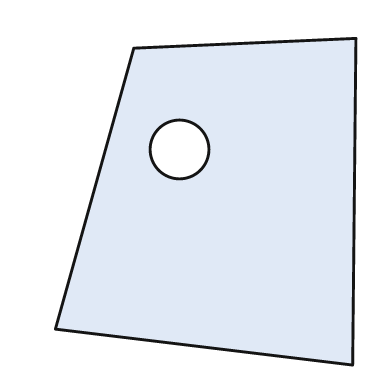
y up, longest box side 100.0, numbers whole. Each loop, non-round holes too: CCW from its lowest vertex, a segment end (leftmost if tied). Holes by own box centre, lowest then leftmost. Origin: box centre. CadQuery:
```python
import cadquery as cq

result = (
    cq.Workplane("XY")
    .moveTo(45.0, -50.0)
    .lineTo(46.0, 50.0)
    .lineTo(-22.0, 47.0)
    .lineTo(-46.0, -39.0)
    .close()
    .moveTo(-8.0, 16.0)
    .circle(9.0)
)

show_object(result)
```